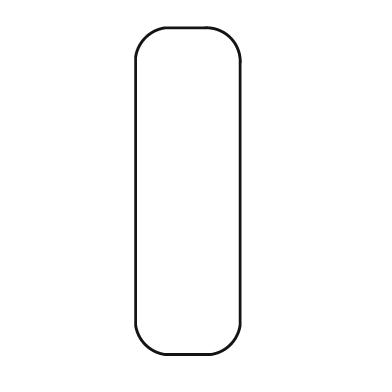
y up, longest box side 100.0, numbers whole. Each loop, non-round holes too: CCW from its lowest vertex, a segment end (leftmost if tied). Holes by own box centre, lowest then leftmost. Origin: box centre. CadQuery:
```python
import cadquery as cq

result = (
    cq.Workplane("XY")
    .moveTo(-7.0, -50.0)
    .lineTo(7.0, -50.0)
    .threePointArc((13.0, -47.0), (16.0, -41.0))
    .lineTo(16.0, 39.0)
    .threePointArc((13.0, 47.0), (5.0, 50.0))
    .lineTo(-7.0, 50.0)
    .threePointArc((-13.0, 47.0), (-16.0, 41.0))
    .lineTo(-16.0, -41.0)
    .threePointArc((-13.0, -47.0), (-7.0, -50.0))
    .close()
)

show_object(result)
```